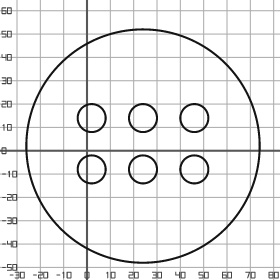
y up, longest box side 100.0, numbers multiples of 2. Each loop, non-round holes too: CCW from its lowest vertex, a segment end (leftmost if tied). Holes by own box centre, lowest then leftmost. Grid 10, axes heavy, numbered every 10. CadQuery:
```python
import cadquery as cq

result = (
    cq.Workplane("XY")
    .moveTo(24.0, 2.0)
    .circle(50.0)
    .moveTo(2.0, -8.0)
    .circle(6.0)
    .moveTo(24.0, -8.0)
    .circle(6.0)
    .moveTo(46.0, -8.0)
    .circle(6.0)
    .moveTo(2.0, 14.0)
    .circle(6.0)
    .moveTo(24.0, 14.0)
    .circle(6.0)
    .moveTo(46.0, 14.0)
    .circle(6.0)
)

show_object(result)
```